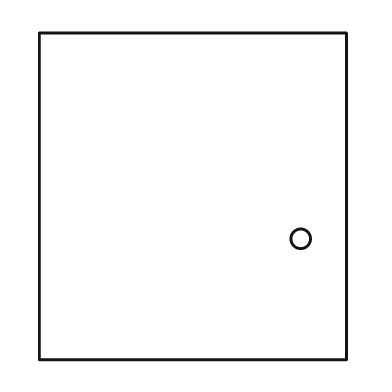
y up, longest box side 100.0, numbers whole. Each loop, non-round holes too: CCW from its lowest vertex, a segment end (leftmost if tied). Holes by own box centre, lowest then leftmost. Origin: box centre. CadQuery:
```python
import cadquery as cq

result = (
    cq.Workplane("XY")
    .moveTo(-47.0, -50.0)
    .lineTo(47.0, -50.0)
    .lineTo(47.0, 50.0)
    .lineTo(-47.0, 50.0)
    .close()
    .moveTo(33.0, -13.0)
    .circle(3.0)
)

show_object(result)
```